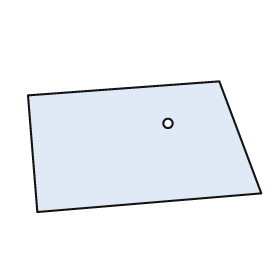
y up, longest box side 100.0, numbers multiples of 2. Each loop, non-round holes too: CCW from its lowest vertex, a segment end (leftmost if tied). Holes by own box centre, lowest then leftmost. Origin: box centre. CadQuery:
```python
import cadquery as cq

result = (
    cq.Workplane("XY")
    .moveTo(-46.0, -28.0)
    .lineTo(50.0, -20.0)
    .lineTo(32.0, 28.0)
    .lineTo(-50.0, 22.0)
    .close()
    .moveTo(10.0, 10.0)
    .circle(2.0)
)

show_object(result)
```